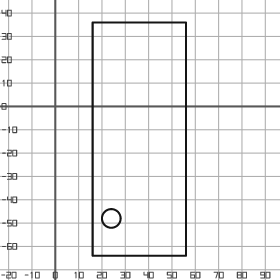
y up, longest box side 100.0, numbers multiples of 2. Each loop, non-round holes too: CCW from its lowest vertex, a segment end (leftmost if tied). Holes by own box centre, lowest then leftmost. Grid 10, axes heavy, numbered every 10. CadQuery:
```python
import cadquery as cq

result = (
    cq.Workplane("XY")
    .moveTo(16.0, -64.0)
    .lineTo(56.0, -64.0)
    .lineTo(56.0, 36.0)
    .lineTo(16.0, 36.0)
    .close()
    .moveTo(24.0, -48.0)
    .circle(4.0)
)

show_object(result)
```